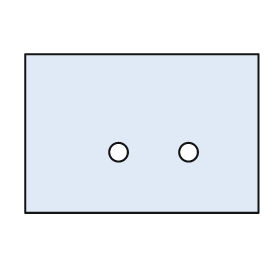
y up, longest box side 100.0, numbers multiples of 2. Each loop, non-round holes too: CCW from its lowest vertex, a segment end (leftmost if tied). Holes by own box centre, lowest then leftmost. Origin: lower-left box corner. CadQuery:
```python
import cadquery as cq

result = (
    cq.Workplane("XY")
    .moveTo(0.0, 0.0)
    .lineTo(100.0, 0.0)
    .lineTo(100.0, 68.0)
    .lineTo(0.0, 68.0)
    .close()
    .moveTo(40.0, 26.0)
    .circle(4.0)
    .moveTo(70.0, 26.0)
    .circle(4.0)
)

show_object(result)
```